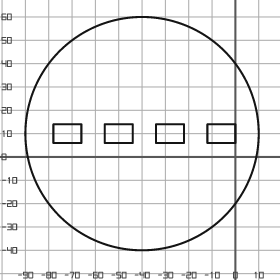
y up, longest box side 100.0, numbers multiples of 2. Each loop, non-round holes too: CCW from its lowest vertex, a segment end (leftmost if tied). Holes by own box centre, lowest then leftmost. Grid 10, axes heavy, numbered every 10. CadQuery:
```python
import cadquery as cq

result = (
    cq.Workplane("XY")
    .moveTo(-40.0, 10.0)
    .circle(50.0)
    .moveTo(-78.0, 6.0)
    .lineTo(-66.0, 6.0)
    .lineTo(-66.0, 14.0)
    .lineTo(-78.0, 14.0)
    .close()
    .moveTo(-56.0, 6.0)
    .lineTo(-44.0, 6.0)
    .lineTo(-44.0, 14.0)
    .lineTo(-56.0, 14.0)
    .close()
    .moveTo(-34.0, 6.0)
    .lineTo(-22.0, 6.0)
    .lineTo(-22.0, 14.0)
    .lineTo(-34.0, 14.0)
    .close()
    .moveTo(-12.0, 6.0)
    .lineTo(0.0, 6.0)
    .lineTo(0.0, 14.0)
    .lineTo(-12.0, 14.0)
    .close()
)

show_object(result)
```